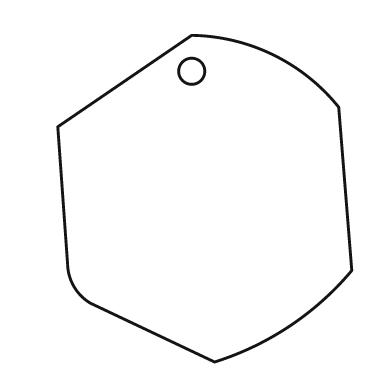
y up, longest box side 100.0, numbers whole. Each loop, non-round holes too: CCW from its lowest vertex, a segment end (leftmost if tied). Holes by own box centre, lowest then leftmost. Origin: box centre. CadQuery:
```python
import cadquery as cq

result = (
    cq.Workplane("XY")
    .moveTo(3.0, -50.0)
    .threePointArc((26.0, -39.0), (45.0, -22.0))
    .lineTo(41.0, 28.0)
    .threePointArc((21.0, 44.0), (-4.0, 50.0))
    .lineTo(-45.0, 22.0)
    .lineTo(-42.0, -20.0)
    .threePointArc((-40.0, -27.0), (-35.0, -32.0))
    .close()
    .moveTo(-4.0, 39.0)
    .circle(4.0)
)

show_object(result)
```